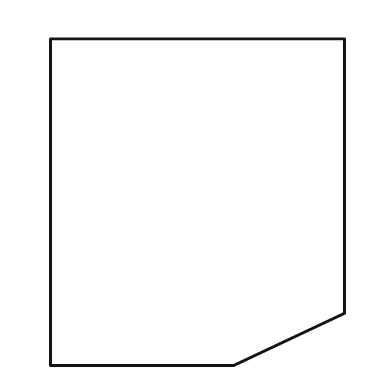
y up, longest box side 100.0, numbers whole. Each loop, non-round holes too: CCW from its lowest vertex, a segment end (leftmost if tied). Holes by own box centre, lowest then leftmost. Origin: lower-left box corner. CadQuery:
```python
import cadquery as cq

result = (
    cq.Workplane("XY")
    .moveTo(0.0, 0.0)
    .lineTo(56.0, 0.0)
    .lineTo(90.0, 16.0)
    .lineTo(90.0, 100.0)
    .lineTo(0.0, 100.0)
    .close()
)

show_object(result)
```